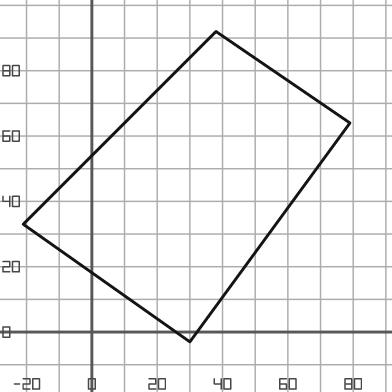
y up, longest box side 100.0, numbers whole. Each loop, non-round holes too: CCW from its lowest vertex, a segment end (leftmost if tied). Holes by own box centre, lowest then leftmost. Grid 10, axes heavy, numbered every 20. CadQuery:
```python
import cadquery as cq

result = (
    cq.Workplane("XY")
    .moveTo(30.0, -3.0)
    .lineTo(79.0, 64.0)
    .lineTo(38.0, 92.0)
    .lineTo(-21.0, 33.0)
    .close()
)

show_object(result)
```